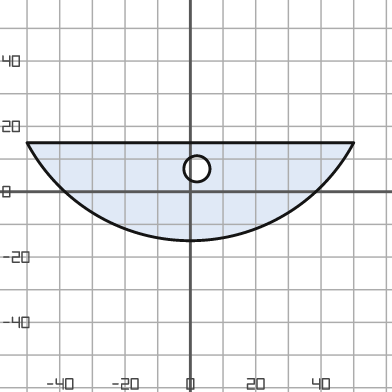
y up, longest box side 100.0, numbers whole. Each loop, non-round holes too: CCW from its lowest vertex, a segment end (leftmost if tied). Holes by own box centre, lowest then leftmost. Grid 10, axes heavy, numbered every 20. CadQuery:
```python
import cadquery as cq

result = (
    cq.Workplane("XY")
    .moveTo(-50.0, 15.0)
    .threePointArc((0.0, -15.0), (50.0, 15.0))
    .close()
    .moveTo(2.0, 7.0)
    .circle(4.0)
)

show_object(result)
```